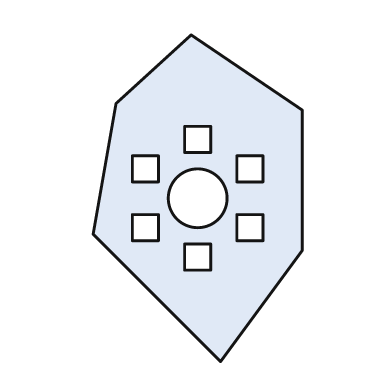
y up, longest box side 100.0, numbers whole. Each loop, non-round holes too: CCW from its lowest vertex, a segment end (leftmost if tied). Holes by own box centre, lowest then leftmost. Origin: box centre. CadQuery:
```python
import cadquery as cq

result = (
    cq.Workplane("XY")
    .moveTo(7.0, -50.0)
    .lineTo(32.0, -16.0)
    .lineTo(32.0, 27.0)
    .lineTo(-2.0, 50.0)
    .lineTo(-25.0, 29.0)
    .lineTo(-32.0, -11.0)
    .close()
    .moveTo(-4.0, -22.0)
    .lineTo(4.0, -22.0)
    .lineTo(4.0, -14.0)
    .lineTo(-4.0, -14.0)
    .close()
    .moveTo(-20.0, -13.0)
    .lineTo(-12.0, -13.0)
    .lineTo(-12.0, -5.0)
    .lineTo(-20.0, -5.0)
    .close()
    .moveTo(12.0, -13.0)
    .lineTo(20.0, -13.0)
    .lineTo(20.0, -5.0)
    .lineTo(12.0, -5.0)
    .close()
    .moveTo(0.0, 0.0)
    .circle(9.0)
    .moveTo(-20.0, 5.0)
    .lineTo(-12.0, 5.0)
    .lineTo(-12.0, 13.0)
    .lineTo(-20.0, 13.0)
    .close()
    .moveTo(12.0, 5.0)
    .lineTo(20.0, 5.0)
    .lineTo(20.0, 13.0)
    .lineTo(12.0, 13.0)
    .close()
    .moveTo(-4.0, 14.0)
    .lineTo(4.0, 14.0)
    .lineTo(4.0, 22.0)
    .lineTo(-4.0, 22.0)
    .close()
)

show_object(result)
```